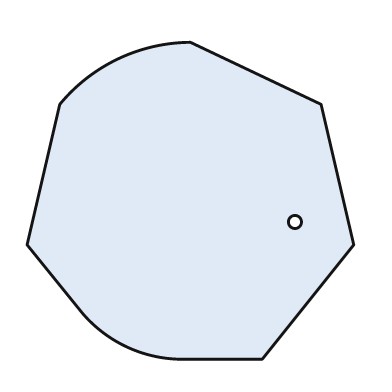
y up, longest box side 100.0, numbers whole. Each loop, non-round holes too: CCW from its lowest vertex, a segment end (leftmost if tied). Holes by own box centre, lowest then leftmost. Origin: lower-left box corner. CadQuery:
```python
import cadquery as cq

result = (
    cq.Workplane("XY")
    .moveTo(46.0, 0.0)
    .lineTo(72.0, 0.0)
    .lineTo(100.0, 35.0)
    .lineTo(90.0, 78.0)
    .lineTo(50.0, 97.0)
    .threePointArc((28.0, 92.0), (10.0, 78.0))
    .lineTo(0.0, 35.0)
    .lineTo(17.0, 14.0)
    .threePointArc((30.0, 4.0), (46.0, 0.0))
    .close()
    .moveTo(82.0, 42.0)
    .circle(2.0)
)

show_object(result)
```